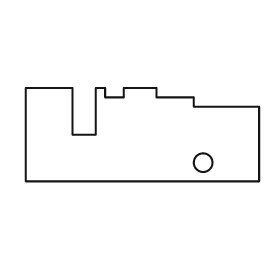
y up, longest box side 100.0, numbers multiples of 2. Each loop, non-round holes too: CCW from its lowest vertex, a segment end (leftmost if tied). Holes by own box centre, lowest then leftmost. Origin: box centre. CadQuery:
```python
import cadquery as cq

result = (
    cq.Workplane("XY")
    .moveTo(-50.0, -20.0)
    .lineTo(50.0, -20.0)
    .lineTo(50.0, 12.0)
    .lineTo(22.0, 12.0)
    .lineTo(22.0, 16.0)
    .lineTo(6.0, 16.0)
    .lineTo(6.0, 20.0)
    .lineTo(-8.0, 20.0)
    .lineTo(-8.0, 16.0)
    .lineTo(-16.0, 16.0)
    .lineTo(-16.0, 20.0)
    .lineTo(-20.0, 20.0)
    .lineTo(-20.0, 0.0)
    .lineTo(-30.0, 0.0)
    .lineTo(-30.0, 20.0)
    .lineTo(-50.0, 20.0)
    .close()
    .moveTo(26.0, -12.0)
    .circle(4.0)
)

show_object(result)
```